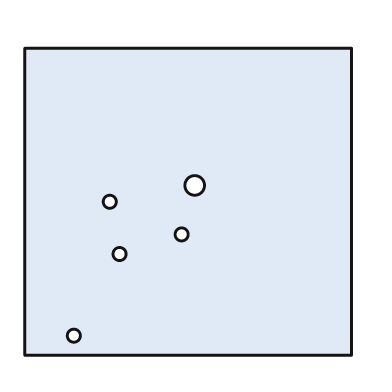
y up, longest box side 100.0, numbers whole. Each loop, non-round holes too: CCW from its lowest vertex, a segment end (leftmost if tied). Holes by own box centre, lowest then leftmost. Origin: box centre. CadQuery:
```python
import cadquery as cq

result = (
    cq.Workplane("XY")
    .moveTo(-50.0, -47.0)
    .lineTo(50.0, -47.0)
    .lineTo(50.0, 47.0)
    .lineTo(-50.0, 47.0)
    .close()
    .moveTo(-35.0, -41.0)
    .circle(2.0)
    .moveTo(-21.0, -16.0)
    .circle(2.0)
    .moveTo(-2.0, -10.0)
    .circle(2.0)
    .moveTo(-24.0, 0.0)
    .circle(2.0)
    .moveTo(2.0, 5.0)
    .circle(3.0)
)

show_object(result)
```